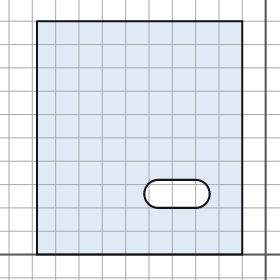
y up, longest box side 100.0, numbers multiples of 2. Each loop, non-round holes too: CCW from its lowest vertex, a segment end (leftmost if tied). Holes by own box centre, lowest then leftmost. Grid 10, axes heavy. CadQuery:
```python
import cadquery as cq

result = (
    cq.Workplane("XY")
    .moveTo(-98.0, 0.0)
    .lineTo(-10.0, 0.0)
    .lineTo(-10.0, 100.0)
    .lineTo(-98.0, 100.0)
    .close()
    .moveTo(-46.0, 20.0)
    .lineTo(-30.0, 20.0)
    .threePointArc((-24.0, 26.0), (-30.0, 32.0))
    .lineTo(-46.0, 32.0)
    .threePointArc((-52.0, 26.0), (-46.0, 20.0))
    .close()
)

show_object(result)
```